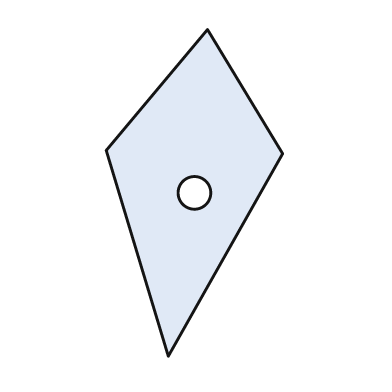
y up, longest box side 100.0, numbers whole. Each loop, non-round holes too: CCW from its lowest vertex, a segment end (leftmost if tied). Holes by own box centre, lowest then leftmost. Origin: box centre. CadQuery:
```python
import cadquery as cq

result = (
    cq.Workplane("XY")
    .moveTo(-8.0, -50.0)
    .lineTo(27.0, 12.0)
    .lineTo(4.0, 50.0)
    .lineTo(-27.0, 13.0)
    .close()
    .moveTo(0.0, 0.0)
    .circle(5.0)
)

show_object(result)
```